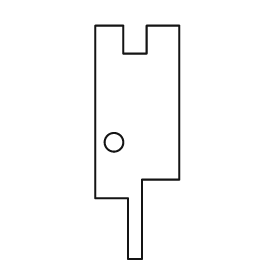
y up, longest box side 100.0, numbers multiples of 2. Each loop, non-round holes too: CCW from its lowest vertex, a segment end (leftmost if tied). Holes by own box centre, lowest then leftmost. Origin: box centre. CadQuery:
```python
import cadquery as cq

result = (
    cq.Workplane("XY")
    .moveTo(-4.0, -50.0)
    .lineTo(2.0, -50.0)
    .lineTo(2.0, -16.0)
    .lineTo(18.0, -16.0)
    .lineTo(18.0, 50.0)
    .lineTo(4.0, 50.0)
    .lineTo(4.0, 38.0)
    .lineTo(-6.0, 38.0)
    .lineTo(-6.0, 50.0)
    .lineTo(-18.0, 50.0)
    .lineTo(-18.0, -24.0)
    .lineTo(-4.0, -24.0)
    .close()
    .moveTo(-10.0, 0.0)
    .circle(4.0)
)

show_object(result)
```